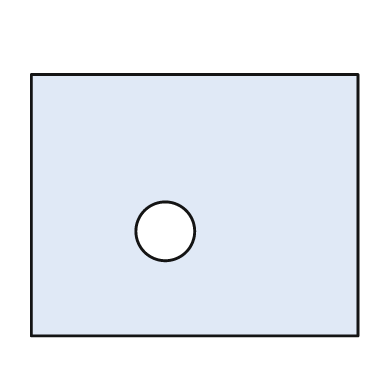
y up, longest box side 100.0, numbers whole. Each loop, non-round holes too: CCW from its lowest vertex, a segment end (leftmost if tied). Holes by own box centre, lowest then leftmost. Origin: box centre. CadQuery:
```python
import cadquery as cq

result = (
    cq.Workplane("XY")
    .moveTo(-50.0, -40.0)
    .lineTo(50.0, -40.0)
    .lineTo(50.0, 40.0)
    .lineTo(-50.0, 40.0)
    .close()
    .moveTo(-9.0, -8.0)
    .circle(9.0)
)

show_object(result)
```